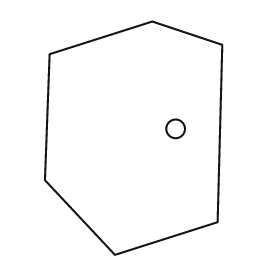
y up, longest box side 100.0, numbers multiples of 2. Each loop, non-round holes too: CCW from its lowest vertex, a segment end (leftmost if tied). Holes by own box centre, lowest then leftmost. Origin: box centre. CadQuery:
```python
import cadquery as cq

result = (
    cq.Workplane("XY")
    .moveTo(-8.0, -50.0)
    .lineTo(36.0, -36.0)
    .lineTo(38.0, 40.0)
    .lineTo(8.0, 50.0)
    .lineTo(-36.0, 36.0)
    .lineTo(-38.0, -18.0)
    .close()
    .moveTo(18.0, 4.0)
    .circle(4.0)
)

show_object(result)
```